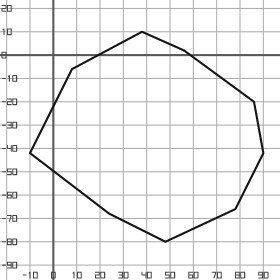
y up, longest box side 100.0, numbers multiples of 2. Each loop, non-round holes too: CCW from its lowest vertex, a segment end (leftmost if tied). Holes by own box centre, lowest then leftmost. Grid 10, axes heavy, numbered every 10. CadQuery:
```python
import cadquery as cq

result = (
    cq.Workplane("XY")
    .moveTo(48.0, -80.0)
    .lineTo(78.0, -66.0)
    .lineTo(90.0, -42.0)
    .lineTo(86.0, -20.0)
    .lineTo(56.0, 2.0)
    .lineTo(38.0, 10.0)
    .lineTo(8.0, -6.0)
    .lineTo(-10.0, -42.0)
    .lineTo(24.0, -68.0)
    .close()
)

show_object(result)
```